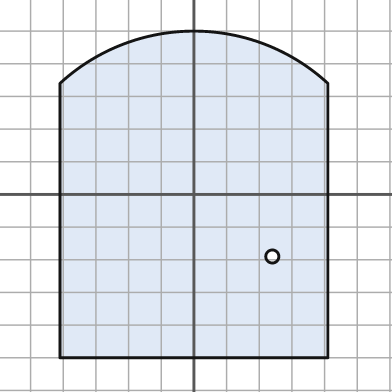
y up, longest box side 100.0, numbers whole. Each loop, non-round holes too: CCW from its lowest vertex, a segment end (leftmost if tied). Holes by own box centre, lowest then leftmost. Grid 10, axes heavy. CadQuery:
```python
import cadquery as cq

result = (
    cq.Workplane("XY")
    .moveTo(-41.0, -50.0)
    .lineTo(41.0, -50.0)
    .lineTo(41.0, 34.0)
    .threePointArc((0.0, 50.0), (-41.0, 34.0))
    .close()
    .moveTo(24.0, -19.0)
    .circle(2.0)
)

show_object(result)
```